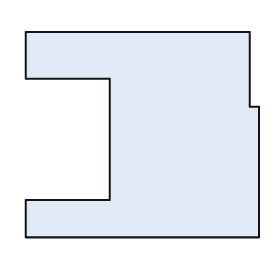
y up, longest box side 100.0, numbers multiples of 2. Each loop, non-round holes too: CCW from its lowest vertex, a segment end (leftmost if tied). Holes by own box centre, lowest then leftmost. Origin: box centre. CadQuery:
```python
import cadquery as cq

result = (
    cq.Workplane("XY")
    .moveTo(-50.0, -44.0)
    .lineTo(50.0, -44.0)
    .lineTo(50.0, 12.0)
    .lineTo(46.0, 12.0)
    .lineTo(46.0, 44.0)
    .lineTo(-50.0, 44.0)
    .lineTo(-50.0, 24.0)
    .lineTo(-14.0, 24.0)
    .lineTo(-14.0, -28.0)
    .lineTo(-50.0, -28.0)
    .close()
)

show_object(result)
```